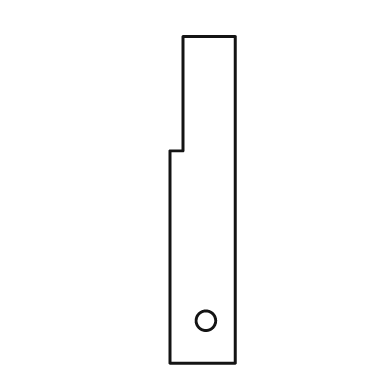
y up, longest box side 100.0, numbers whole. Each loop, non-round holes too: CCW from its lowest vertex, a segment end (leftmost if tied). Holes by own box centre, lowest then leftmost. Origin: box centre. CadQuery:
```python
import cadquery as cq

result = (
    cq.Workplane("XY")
    .moveTo(-10.0, -50.0)
    .lineTo(10.0, -50.0)
    .lineTo(10.0, 50.0)
    .lineTo(-6.0, 50.0)
    .lineTo(-6.0, 15.0)
    .lineTo(-10.0, 15.0)
    .close()
    .moveTo(1.0, -37.0)
    .circle(3.0)
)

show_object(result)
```